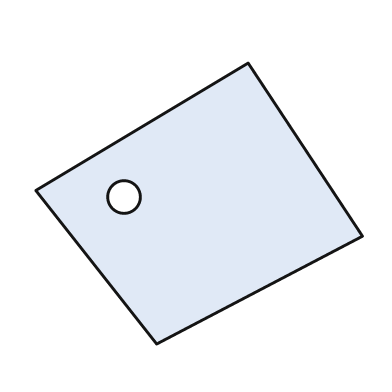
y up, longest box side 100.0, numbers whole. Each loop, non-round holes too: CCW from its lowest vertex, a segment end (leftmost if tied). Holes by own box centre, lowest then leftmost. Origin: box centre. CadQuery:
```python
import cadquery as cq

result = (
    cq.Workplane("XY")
    .moveTo(-13.0, -43.0)
    .lineTo(50.0, -10.0)
    .lineTo(15.0, 43.0)
    .lineTo(-50.0, 4.0)
    .close()
    .moveTo(-23.0, 2.0)
    .circle(5.0)
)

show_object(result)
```